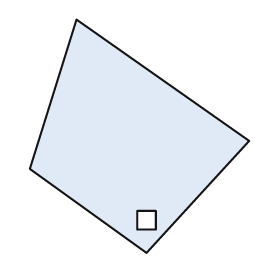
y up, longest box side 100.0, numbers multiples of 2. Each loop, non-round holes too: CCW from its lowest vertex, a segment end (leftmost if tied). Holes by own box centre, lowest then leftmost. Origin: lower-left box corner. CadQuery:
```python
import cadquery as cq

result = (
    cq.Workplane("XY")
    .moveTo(50.0, 0.0)
    .lineTo(94.0, 48.0)
    .lineTo(20.0, 100.0)
    .lineTo(0.0, 36.0)
    .close()
    .moveTo(46.0, 10.0)
    .lineTo(54.0, 10.0)
    .lineTo(54.0, 18.0)
    .lineTo(46.0, 18.0)
    .close()
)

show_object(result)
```